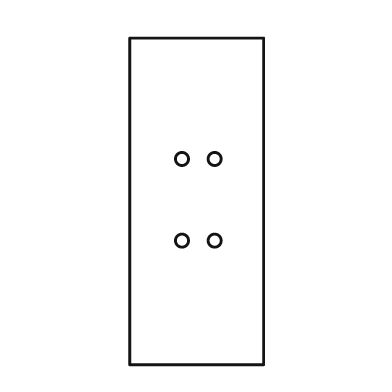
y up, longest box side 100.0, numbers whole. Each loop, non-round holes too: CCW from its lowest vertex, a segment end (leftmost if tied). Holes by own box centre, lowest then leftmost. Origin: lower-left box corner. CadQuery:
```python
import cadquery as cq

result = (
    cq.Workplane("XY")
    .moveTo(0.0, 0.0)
    .lineTo(41.0, 0.0)
    .lineTo(41.0, 100.0)
    .lineTo(0.0, 100.0)
    .close()
    .moveTo(16.0, 38.0)
    .circle(2.0)
    .moveTo(26.0, 38.0)
    .circle(2.0)
    .moveTo(16.0, 63.0)
    .circle(2.0)
    .moveTo(26.0, 63.0)
    .circle(2.0)
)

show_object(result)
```